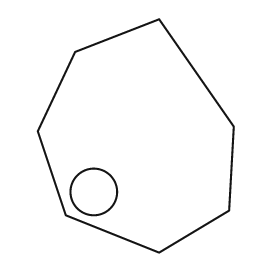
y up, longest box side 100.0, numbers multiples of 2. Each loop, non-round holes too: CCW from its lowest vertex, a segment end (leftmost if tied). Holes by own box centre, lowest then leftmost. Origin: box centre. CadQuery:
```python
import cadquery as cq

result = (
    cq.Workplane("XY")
    .moveTo(10.0, -50.0)
    .lineTo(40.0, -32.0)
    .lineTo(42.0, 4.0)
    .lineTo(10.0, 50.0)
    .lineTo(-26.0, 36.0)
    .lineTo(-42.0, 2.0)
    .lineTo(-30.0, -34.0)
    .close()
    .moveTo(-18.0, -24.0)
    .circle(10.0)
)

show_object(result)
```